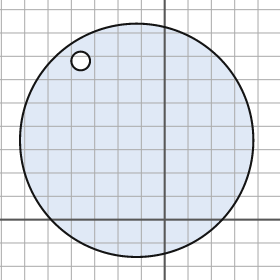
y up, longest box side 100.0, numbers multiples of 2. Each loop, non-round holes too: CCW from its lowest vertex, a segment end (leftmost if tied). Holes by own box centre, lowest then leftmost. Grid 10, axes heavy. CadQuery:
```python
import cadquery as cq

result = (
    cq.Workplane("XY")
    .moveTo(-12.0, 34.0)
    .circle(50.0)
    .moveTo(-36.0, 68.0)
    .circle(4.0)
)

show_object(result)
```